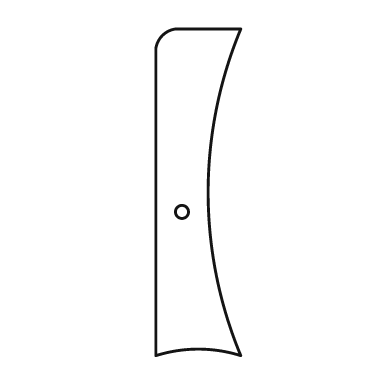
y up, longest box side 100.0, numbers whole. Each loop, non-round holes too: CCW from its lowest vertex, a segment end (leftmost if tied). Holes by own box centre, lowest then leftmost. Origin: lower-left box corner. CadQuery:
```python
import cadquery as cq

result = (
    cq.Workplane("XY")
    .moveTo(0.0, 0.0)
    .threePointArc((13.0, 2.0), (26.0, 0.0))
    .threePointArc((16.0, 50.0), (26.0, 100.0))
    .lineTo(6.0, 100.0)
    .threePointArc((2.0, 98.0), (0.0, 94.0))
    .close()
    .moveTo(8.0, 44.0)
    .circle(2.0)
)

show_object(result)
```